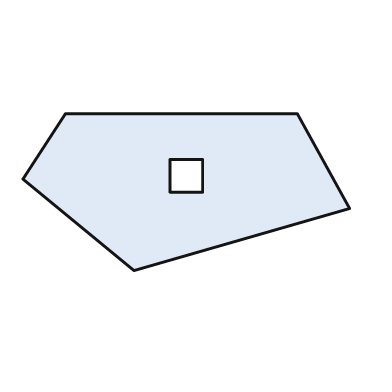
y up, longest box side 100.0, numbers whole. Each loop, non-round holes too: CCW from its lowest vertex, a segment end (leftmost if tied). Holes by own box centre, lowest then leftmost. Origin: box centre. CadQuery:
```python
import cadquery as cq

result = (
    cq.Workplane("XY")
    .moveTo(-16.0, -24.0)
    .lineTo(50.0, -5.0)
    .lineTo(34.0, 24.0)
    .lineTo(-37.0, 24.0)
    .lineTo(-50.0, 4.0)
    .close()
    .moveTo(-5.0, 0.0)
    .lineTo(5.0, 0.0)
    .lineTo(5.0, 10.0)
    .lineTo(-5.0, 10.0)
    .close()
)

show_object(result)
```